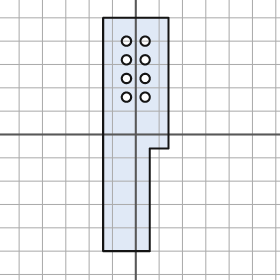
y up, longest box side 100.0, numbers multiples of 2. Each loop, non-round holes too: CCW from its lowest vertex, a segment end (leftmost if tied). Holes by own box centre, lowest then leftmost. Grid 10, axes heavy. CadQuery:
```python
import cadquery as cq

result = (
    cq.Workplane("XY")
    .moveTo(-14.0, -50.0)
    .lineTo(6.0, -50.0)
    .lineTo(6.0, -6.0)
    .lineTo(14.0, -6.0)
    .lineTo(14.0, 50.0)
    .lineTo(-14.0, 50.0)
    .close()
    .moveTo(-4.0, 16.0)
    .circle(2.0)
    .moveTo(4.0, 16.0)
    .circle(2.0)
    .moveTo(-4.0, 24.0)
    .circle(2.0)
    .moveTo(4.0, 24.0)
    .circle(2.0)
    .moveTo(-4.0, 32.0)
    .circle(2.0)
    .moveTo(4.0, 32.0)
    .circle(2.0)
    .moveTo(-4.0, 40.0)
    .circle(2.0)
    .moveTo(4.0, 40.0)
    .circle(2.0)
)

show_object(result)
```